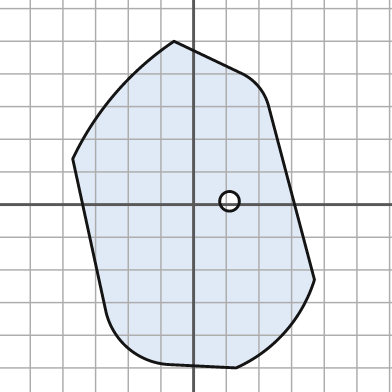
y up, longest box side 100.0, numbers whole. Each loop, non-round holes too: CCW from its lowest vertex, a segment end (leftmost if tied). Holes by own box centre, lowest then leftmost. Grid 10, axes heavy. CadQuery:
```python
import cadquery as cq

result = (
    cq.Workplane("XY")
    .moveTo(13.0, -50.0)
    .threePointArc((28.0, -39.0), (37.0, -23.0))
    .lineTo(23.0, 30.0)
    .threePointArc((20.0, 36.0), (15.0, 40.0))
    .lineTo(-6.0, 50.0)
    .threePointArc((-24.0, 34.0), (-37.0, 14.0))
    .lineTo(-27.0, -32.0)
    .threePointArc((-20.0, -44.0), (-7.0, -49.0))
    .close()
    .moveTo(11.0, 1.0)
    .circle(3.0)
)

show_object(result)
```